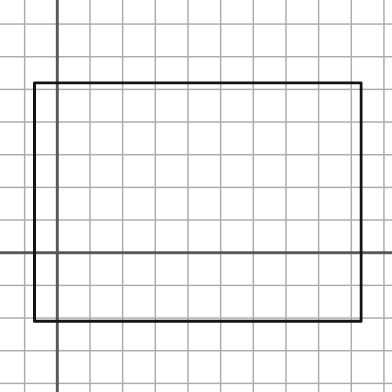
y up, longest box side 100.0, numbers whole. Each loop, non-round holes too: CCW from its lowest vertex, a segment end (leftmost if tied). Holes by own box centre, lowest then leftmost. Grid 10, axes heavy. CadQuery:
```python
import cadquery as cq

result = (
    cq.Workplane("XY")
    .moveTo(-7.0, -21.0)
    .lineTo(93.0, -21.0)
    .lineTo(93.0, 52.0)
    .lineTo(-7.0, 52.0)
    .close()
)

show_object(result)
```